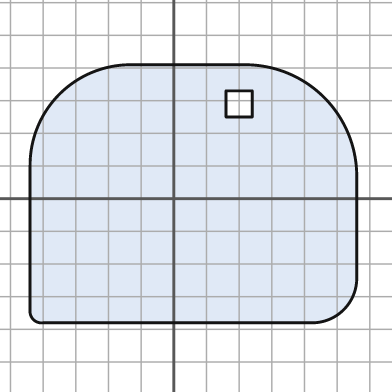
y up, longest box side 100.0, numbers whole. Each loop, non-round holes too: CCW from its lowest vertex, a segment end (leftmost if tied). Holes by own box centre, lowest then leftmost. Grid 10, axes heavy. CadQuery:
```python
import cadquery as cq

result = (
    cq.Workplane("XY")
    .moveTo(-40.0, -38.0)
    .lineTo(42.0, -38.0)
    .threePointArc((52.0, -34.0), (56.0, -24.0))
    .lineTo(56.0, 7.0)
    .threePointArc((46.0, 31.0), (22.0, 41.0))
    .lineTo(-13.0, 41.0)
    .threePointArc((-35.0, 32.0), (-44.0, 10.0))
    .lineTo(-44.0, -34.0)
    .threePointArc((-43.0, -37.0), (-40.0, -38.0))
    .close()
    .moveTo(16.0, 25.0)
    .lineTo(24.0, 25.0)
    .lineTo(24.0, 33.0)
    .lineTo(16.0, 33.0)
    .close()
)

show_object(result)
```